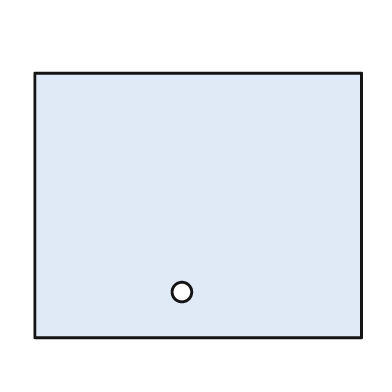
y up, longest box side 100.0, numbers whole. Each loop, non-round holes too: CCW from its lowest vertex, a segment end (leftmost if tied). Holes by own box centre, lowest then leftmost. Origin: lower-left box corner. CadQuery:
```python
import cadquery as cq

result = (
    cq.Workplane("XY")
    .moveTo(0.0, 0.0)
    .lineTo(100.0, 0.0)
    .lineTo(100.0, 81.0)
    .lineTo(0.0, 81.0)
    .close()
    .moveTo(45.0, 14.0)
    .circle(3.0)
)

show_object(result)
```